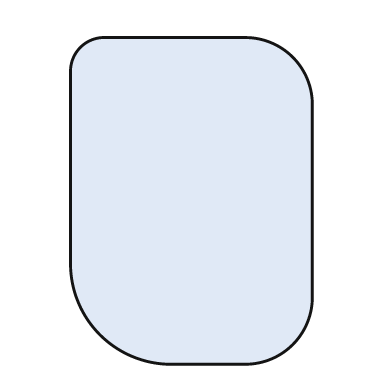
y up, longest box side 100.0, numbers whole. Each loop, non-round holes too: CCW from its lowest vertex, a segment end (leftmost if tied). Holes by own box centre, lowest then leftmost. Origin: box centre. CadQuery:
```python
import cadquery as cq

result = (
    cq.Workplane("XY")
    .moveTo(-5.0, -50.0)
    .lineTo(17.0, -50.0)
    .threePointArc((31.0, -44.0), (37.0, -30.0))
    .lineTo(37.0, 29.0)
    .threePointArc((31.0, 44.0), (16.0, 50.0))
    .lineTo(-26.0, 50.0)
    .threePointArc((-34.0, 47.0), (-37.0, 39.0))
    .lineTo(-37.0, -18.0)
    .threePointArc((-28.0, -41.0), (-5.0, -50.0))
    .close()
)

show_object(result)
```